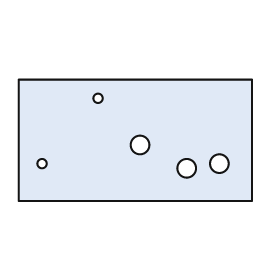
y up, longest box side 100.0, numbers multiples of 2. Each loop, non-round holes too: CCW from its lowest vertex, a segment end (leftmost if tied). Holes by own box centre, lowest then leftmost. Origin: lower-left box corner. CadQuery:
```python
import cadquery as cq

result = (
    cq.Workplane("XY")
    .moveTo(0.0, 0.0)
    .lineTo(100.0, 0.0)
    .lineTo(100.0, 52.0)
    .lineTo(0.0, 52.0)
    .close()
    .moveTo(72.0, 14.0)
    .circle(4.0)
    .moveTo(10.0, 16.0)
    .circle(2.0)
    .moveTo(86.0, 16.0)
    .circle(4.0)
    .moveTo(52.0, 24.0)
    .circle(4.0)
    .moveTo(34.0, 44.0)
    .circle(2.0)
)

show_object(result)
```